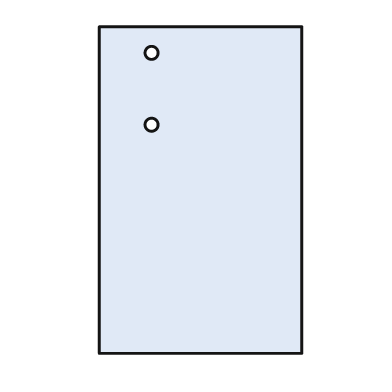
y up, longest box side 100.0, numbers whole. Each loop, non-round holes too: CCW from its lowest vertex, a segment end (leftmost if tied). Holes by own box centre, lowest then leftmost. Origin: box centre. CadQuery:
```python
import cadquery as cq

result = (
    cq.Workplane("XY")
    .moveTo(-31.0, -50.0)
    .lineTo(31.0, -50.0)
    .lineTo(31.0, 50.0)
    .lineTo(-31.0, 50.0)
    .close()
    .moveTo(-15.0, 20.0)
    .circle(2.0)
    .moveTo(-15.0, 42.0)
    .circle(2.0)
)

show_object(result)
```